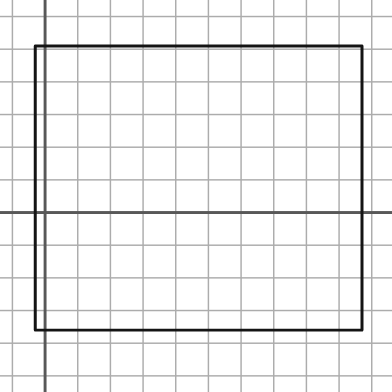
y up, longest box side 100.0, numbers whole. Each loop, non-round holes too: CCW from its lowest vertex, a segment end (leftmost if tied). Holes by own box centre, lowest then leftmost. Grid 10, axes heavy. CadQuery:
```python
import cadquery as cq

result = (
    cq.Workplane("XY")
    .moveTo(-3.0, -36.0)
    .lineTo(97.0, -36.0)
    .lineTo(97.0, 51.0)
    .lineTo(-3.0, 51.0)
    .close()
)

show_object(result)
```